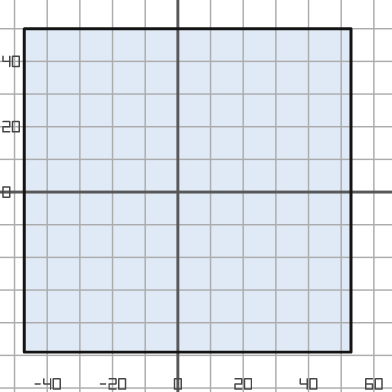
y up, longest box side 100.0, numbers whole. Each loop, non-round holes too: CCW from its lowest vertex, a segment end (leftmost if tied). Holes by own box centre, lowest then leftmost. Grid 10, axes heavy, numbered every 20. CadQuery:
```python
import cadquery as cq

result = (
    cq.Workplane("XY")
    .moveTo(-47.0, -49.0)
    .lineTo(53.0, -49.0)
    .lineTo(53.0, 50.0)
    .lineTo(-47.0, 50.0)
    .close()
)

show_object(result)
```